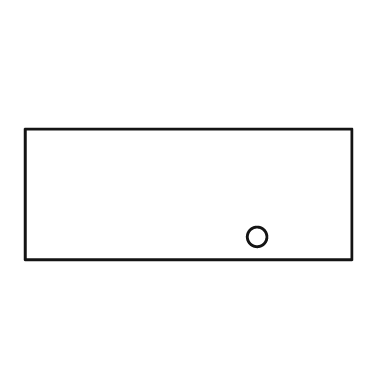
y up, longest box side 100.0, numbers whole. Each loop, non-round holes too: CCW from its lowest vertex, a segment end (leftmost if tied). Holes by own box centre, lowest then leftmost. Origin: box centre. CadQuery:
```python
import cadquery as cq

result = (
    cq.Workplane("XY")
    .moveTo(-50.0, -20.0)
    .lineTo(50.0, -20.0)
    .lineTo(50.0, 20.0)
    .lineTo(-50.0, 20.0)
    .close()
    .moveTo(21.0, -13.0)
    .circle(3.0)
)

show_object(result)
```